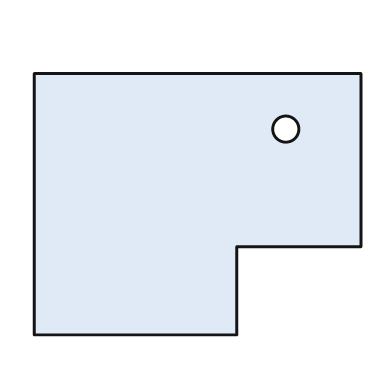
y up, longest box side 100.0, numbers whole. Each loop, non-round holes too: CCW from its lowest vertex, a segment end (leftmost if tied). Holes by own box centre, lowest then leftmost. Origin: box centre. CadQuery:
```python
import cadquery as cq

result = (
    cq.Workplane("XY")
    .moveTo(-50.0, -40.0)
    .lineTo(12.0, -40.0)
    .lineTo(12.0, -13.0)
    .lineTo(50.0, -13.0)
    .lineTo(50.0, 40.0)
    .lineTo(-50.0, 40.0)
    .close()
    .moveTo(27.0, 23.0)
    .circle(4.0)
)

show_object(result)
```